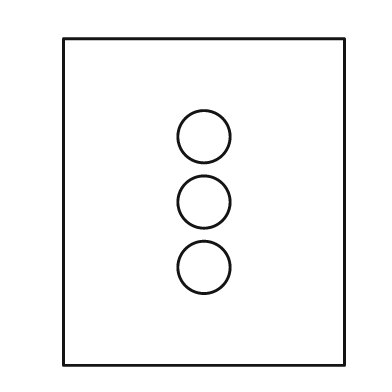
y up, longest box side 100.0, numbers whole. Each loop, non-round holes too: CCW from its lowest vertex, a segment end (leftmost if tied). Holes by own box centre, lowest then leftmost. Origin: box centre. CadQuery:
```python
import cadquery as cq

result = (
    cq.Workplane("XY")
    .moveTo(-43.0, -50.0)
    .lineTo(43.0, -50.0)
    .lineTo(43.0, 50.0)
    .lineTo(-43.0, 50.0)
    .close()
    .moveTo(0.0, -20.0)
    .circle(8.0)
    .moveTo(0.0, 0.0)
    .circle(8.0)
    .moveTo(0.0, 20.0)
    .circle(8.0)
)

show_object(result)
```